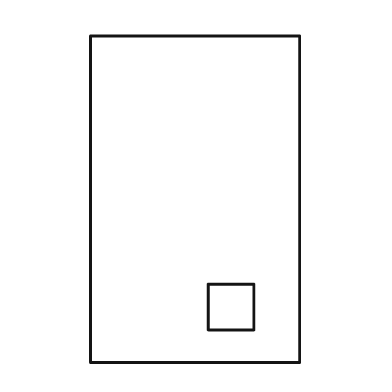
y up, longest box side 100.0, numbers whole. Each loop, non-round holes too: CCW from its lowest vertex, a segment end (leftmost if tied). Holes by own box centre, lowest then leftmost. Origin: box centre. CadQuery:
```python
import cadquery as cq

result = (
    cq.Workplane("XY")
    .moveTo(-32.0, -50.0)
    .lineTo(32.0, -50.0)
    .lineTo(32.0, 50.0)
    .lineTo(-32.0, 50.0)
    .close()
    .moveTo(4.0, -40.0)
    .lineTo(18.0, -40.0)
    .lineTo(18.0, -26.0)
    .lineTo(4.0, -26.0)
    .close()
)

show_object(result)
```